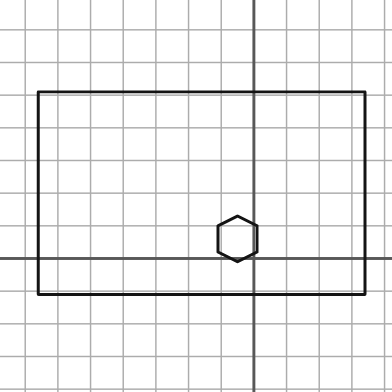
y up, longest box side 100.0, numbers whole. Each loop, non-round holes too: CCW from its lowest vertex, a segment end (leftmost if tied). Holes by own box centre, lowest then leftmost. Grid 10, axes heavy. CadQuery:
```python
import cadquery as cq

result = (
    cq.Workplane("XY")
    .moveTo(-66.0, -11.0)
    .lineTo(34.0, -11.0)
    .lineTo(34.0, 51.0)
    .lineTo(-66.0, 51.0)
    .close()
    .moveTo(-5.0, -1.0)
    .lineTo(1.0, 2.0)
    .lineTo(1.0, 10.0)
    .lineTo(-5.0, 13.0)
    .lineTo(-11.0, 10.0)
    .lineTo(-11.0, 2.0)
    .close()
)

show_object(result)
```